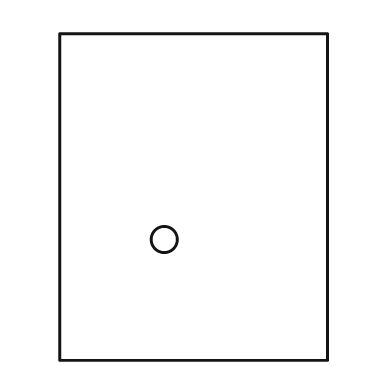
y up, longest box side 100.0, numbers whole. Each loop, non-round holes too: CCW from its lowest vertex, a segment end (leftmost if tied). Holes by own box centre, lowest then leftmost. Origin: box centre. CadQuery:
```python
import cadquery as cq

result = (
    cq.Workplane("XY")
    .moveTo(-41.0, -50.0)
    .lineTo(41.0, -50.0)
    .lineTo(41.0, 50.0)
    .lineTo(-41.0, 50.0)
    .close()
    .moveTo(-9.0, -13.0)
    .circle(4.0)
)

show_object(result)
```